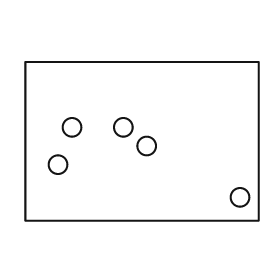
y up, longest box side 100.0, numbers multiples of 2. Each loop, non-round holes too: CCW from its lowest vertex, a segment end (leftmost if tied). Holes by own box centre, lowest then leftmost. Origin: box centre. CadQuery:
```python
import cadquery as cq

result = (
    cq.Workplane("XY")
    .moveTo(-50.0, -34.0)
    .lineTo(50.0, -34.0)
    .lineTo(50.0, 34.0)
    .lineTo(-50.0, 34.0)
    .close()
    .moveTo(42.0, -24.0)
    .circle(4.0)
    .moveTo(-36.0, -10.0)
    .circle(4.0)
    .moveTo(2.0, -2.0)
    .circle(4.0)
    .moveTo(-30.0, 6.0)
    .circle(4.0)
    .moveTo(-8.0, 6.0)
    .circle(4.0)
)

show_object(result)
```